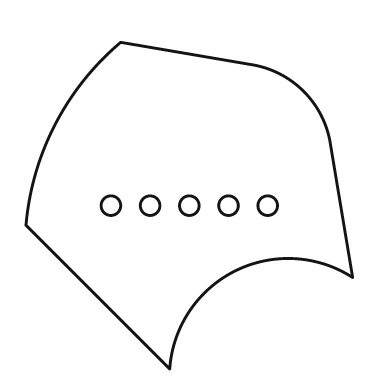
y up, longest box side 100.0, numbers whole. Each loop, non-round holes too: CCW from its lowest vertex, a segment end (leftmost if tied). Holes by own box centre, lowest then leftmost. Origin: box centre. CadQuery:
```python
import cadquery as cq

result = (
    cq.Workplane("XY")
    .moveTo(-6.0, -50.0)
    .threePointArc((14.0, -20.0), (50.0, -22.0))
    .lineTo(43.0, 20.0)
    .threePointArc((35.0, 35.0), (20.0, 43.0))
    .lineTo(-21.0, 50.0)
    .threePointArc((-41.0, 25.0), (-50.0, -6.0))
    .close()
    .moveTo(-24.0, 0.0)
    .circle(3.0)
    .moveTo(-12.0, 0.0)
    .circle(3.0)
    .moveTo(0.0, 0.0)
    .circle(3.0)
    .moveTo(12.0, 0.0)
    .circle(3.0)
    .moveTo(24.0, 0.0)
    .circle(3.0)
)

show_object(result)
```